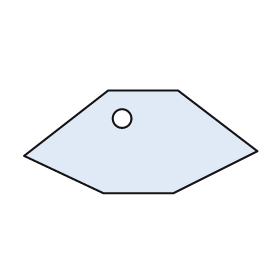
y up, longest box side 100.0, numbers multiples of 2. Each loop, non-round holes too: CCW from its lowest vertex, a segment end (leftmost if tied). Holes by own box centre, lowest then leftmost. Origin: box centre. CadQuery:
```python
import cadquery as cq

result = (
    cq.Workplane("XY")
    .moveTo(-16.0, -22.0)
    .lineTo(14.0, -22.0)
    .lineTo(50.0, -4.0)
    .lineTo(16.0, 22.0)
    .lineTo(-14.0, 22.0)
    .lineTo(-50.0, -6.0)
    .close()
    .moveTo(-8.0, 10.0)
    .circle(4.0)
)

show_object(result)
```